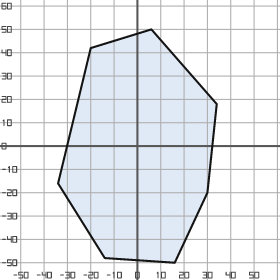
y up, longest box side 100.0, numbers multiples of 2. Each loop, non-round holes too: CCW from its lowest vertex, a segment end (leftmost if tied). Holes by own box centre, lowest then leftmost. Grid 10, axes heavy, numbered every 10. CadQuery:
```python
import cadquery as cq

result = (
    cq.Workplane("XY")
    .moveTo(16.0, -50.0)
    .lineTo(30.0, -20.0)
    .lineTo(34.0, 18.0)
    .lineTo(6.0, 50.0)
    .lineTo(-20.0, 42.0)
    .lineTo(-34.0, -16.0)
    .lineTo(-14.0, -48.0)
    .close()
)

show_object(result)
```